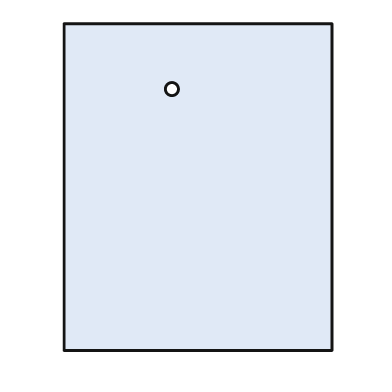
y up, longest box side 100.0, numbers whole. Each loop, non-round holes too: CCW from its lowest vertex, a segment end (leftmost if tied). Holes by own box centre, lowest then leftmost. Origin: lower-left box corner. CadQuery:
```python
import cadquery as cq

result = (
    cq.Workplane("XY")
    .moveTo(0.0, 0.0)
    .lineTo(82.0, 0.0)
    .lineTo(82.0, 100.0)
    .lineTo(0.0, 100.0)
    .close()
    .moveTo(33.0, 80.0)
    .circle(2.0)
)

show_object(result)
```